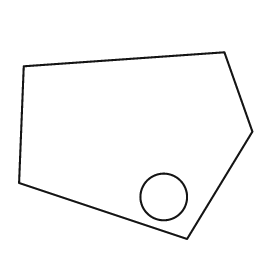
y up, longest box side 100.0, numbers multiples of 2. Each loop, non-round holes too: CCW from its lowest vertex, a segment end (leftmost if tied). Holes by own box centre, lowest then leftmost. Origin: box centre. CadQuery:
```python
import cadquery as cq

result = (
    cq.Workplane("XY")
    .moveTo(22.0, -40.0)
    .lineTo(50.0, 6.0)
    .lineTo(38.0, 40.0)
    .lineTo(-48.0, 34.0)
    .lineTo(-50.0, -16.0)
    .close()
    .moveTo(12.0, -22.0)
    .circle(10.0)
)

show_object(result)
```